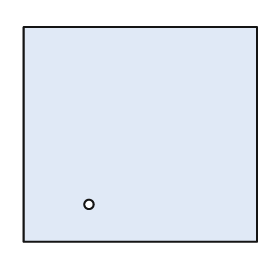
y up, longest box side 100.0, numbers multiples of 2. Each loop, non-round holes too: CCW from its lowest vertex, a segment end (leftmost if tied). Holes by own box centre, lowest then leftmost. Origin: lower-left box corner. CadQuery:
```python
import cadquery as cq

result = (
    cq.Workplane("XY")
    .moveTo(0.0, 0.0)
    .lineTo(100.0, 0.0)
    .lineTo(100.0, 92.0)
    .lineTo(0.0, 92.0)
    .close()
    .moveTo(28.0, 16.0)
    .circle(2.0)
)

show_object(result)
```